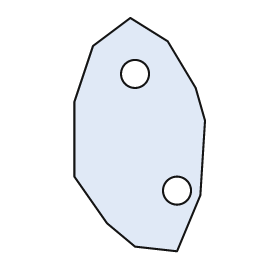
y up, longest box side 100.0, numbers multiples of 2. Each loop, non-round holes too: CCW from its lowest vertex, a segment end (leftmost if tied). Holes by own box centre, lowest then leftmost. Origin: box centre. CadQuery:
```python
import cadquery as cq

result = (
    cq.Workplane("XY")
    .moveTo(16.0, -50.0)
    .lineTo(26.0, -26.0)
    .lineTo(28.0, 6.0)
    .lineTo(24.0, 20.0)
    .lineTo(12.0, 40.0)
    .lineTo(-4.0, 50.0)
    .lineTo(-20.0, 38.0)
    .lineTo(-28.0, 14.0)
    .lineTo(-28.0, -18.0)
    .lineTo(-14.0, -38.0)
    .lineTo(-2.0, -48.0)
    .close()
    .moveTo(16.0, -24.0)
    .circle(6.0)
    .moveTo(-2.0, 26.0)
    .circle(6.0)
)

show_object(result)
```